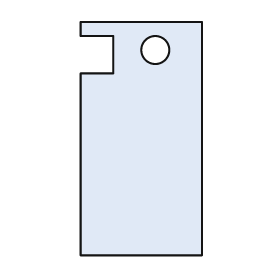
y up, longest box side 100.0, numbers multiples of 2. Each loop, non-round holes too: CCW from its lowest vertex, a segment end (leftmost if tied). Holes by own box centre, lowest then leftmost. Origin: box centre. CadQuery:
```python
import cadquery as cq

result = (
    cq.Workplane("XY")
    .moveTo(-26.0, -50.0)
    .lineTo(26.0, -50.0)
    .lineTo(26.0, 50.0)
    .lineTo(-26.0, 50.0)
    .lineTo(-26.0, 44.0)
    .lineTo(-12.0, 44.0)
    .lineTo(-12.0, 28.0)
    .lineTo(-26.0, 28.0)
    .close()
    .moveTo(6.0, 38.0)
    .circle(6.0)
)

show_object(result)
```